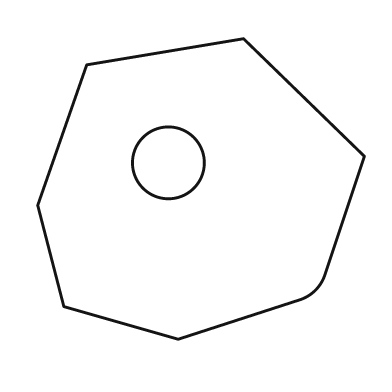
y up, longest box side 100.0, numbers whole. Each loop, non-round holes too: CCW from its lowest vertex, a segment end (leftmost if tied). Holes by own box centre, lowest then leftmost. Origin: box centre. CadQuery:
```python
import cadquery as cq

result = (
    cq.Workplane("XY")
    .moveTo(-7.0, -46.0)
    .lineTo(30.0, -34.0)
    .threePointArc((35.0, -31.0), (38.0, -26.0))
    .lineTo(50.0, 10.0)
    .lineTo(13.0, 46.0)
    .lineTo(-35.0, 38.0)
    .lineTo(-50.0, -5.0)
    .lineTo(-42.0, -36.0)
    .close()
    .moveTo(-10.0, 8.0)
    .circle(11.0)
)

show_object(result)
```